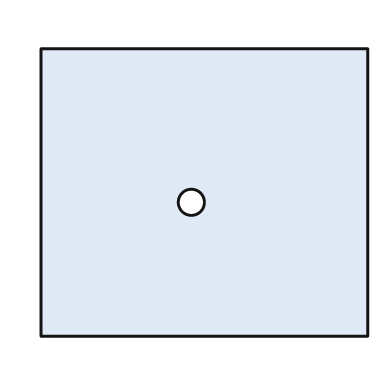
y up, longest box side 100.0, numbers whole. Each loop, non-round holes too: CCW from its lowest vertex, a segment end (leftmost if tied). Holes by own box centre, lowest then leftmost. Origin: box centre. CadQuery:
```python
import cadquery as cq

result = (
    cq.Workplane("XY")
    .moveTo(-50.0, -44.0)
    .lineTo(50.0, -44.0)
    .lineTo(50.0, 44.0)
    .lineTo(-50.0, 44.0)
    .close()
    .moveTo(-4.0, -3.0)
    .circle(4.0)
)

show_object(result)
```